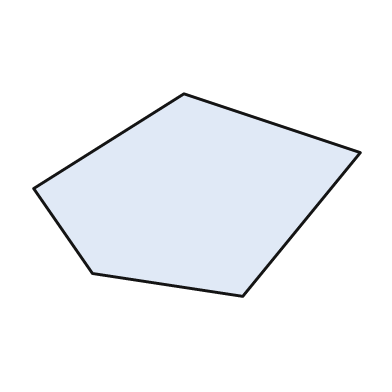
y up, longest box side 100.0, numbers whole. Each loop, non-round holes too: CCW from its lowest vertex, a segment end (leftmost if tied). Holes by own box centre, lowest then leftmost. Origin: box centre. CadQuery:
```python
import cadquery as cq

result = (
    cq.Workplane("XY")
    .moveTo(14.0, -31.0)
    .lineTo(50.0, 13.0)
    .lineTo(-4.0, 31.0)
    .lineTo(-50.0, 2.0)
    .lineTo(-32.0, -24.0)
    .close()
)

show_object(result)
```